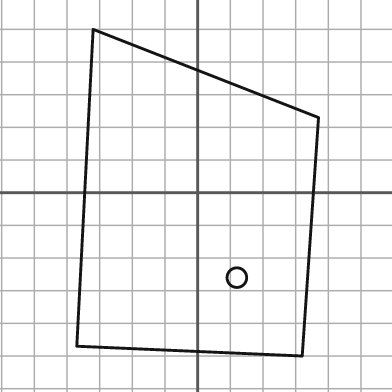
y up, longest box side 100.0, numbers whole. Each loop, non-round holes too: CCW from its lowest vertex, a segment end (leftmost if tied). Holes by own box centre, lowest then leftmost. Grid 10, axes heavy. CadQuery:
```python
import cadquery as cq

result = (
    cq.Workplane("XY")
    .moveTo(32.0, -50.0)
    .lineTo(37.0, 23.0)
    .lineTo(-32.0, 50.0)
    .lineTo(-37.0, -47.0)
    .close()
    .moveTo(12.0, -26.0)
    .circle(3.0)
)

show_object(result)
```